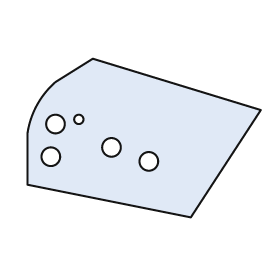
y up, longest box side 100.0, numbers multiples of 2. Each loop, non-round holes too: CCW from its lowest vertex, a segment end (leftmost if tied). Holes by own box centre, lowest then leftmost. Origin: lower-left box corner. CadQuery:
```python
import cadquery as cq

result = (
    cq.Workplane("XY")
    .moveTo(70.0, 0.0)
    .lineTo(100.0, 46.0)
    .lineTo(28.0, 68.0)
    .lineTo(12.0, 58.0)
    .threePointArc((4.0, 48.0), (0.0, 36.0))
    .lineTo(0.0, 14.0)
    .close()
    .moveTo(52.0, 24.0)
    .circle(4.0)
    .moveTo(10.0, 26.0)
    .circle(4.0)
    .moveTo(36.0, 30.0)
    .circle(4.0)
    .moveTo(12.0, 40.0)
    .circle(4.0)
    .moveTo(22.0, 42.0)
    .circle(2.0)
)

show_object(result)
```